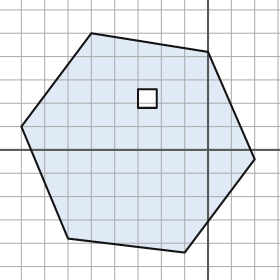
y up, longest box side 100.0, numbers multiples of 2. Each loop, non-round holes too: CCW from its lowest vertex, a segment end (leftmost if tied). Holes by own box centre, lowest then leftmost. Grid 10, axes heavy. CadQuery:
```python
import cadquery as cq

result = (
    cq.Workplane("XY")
    .moveTo(-10.0, -44.0)
    .lineTo(20.0, -4.0)
    .lineTo(0.0, 42.0)
    .lineTo(-50.0, 50.0)
    .lineTo(-80.0, 10.0)
    .lineTo(-60.0, -38.0)
    .close()
    .moveTo(-30.0, 18.0)
    .lineTo(-22.0, 18.0)
    .lineTo(-22.0, 26.0)
    .lineTo(-30.0, 26.0)
    .close()
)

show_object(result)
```